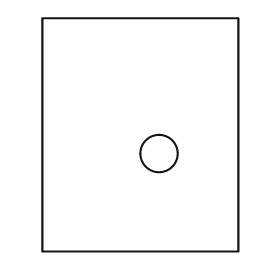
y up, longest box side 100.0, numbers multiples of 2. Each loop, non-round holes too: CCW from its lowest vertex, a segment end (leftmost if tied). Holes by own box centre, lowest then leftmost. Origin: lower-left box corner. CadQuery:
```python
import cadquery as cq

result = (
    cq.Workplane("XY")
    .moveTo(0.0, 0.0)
    .lineTo(84.0, 0.0)
    .lineTo(84.0, 100.0)
    .lineTo(0.0, 100.0)
    .close()
    .moveTo(50.0, 42.0)
    .circle(8.0)
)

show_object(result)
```